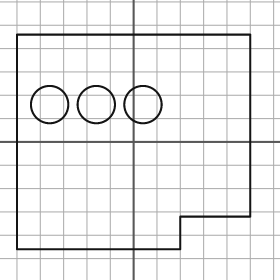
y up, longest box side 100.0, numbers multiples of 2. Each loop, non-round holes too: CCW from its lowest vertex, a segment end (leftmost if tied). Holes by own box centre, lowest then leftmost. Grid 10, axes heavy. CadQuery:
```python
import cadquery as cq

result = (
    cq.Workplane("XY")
    .moveTo(-50.0, -46.0)
    .lineTo(20.0, -46.0)
    .lineTo(20.0, -32.0)
    .lineTo(50.0, -32.0)
    .lineTo(50.0, 46.0)
    .lineTo(-50.0, 46.0)
    .close()
    .moveTo(-36.0, 16.0)
    .circle(8.0)
    .moveTo(-16.0, 16.0)
    .circle(8.0)
    .moveTo(4.0, 16.0)
    .circle(8.0)
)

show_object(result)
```